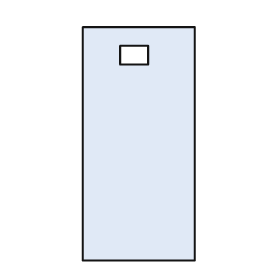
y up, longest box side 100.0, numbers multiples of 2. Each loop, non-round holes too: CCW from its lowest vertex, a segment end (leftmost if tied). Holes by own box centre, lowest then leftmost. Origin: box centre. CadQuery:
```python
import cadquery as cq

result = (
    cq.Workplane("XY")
    .moveTo(-24.0, -50.0)
    .lineTo(24.0, -50.0)
    .lineTo(24.0, 50.0)
    .lineTo(-24.0, 50.0)
    .close()
    .moveTo(-8.0, 34.0)
    .lineTo(4.0, 34.0)
    .lineTo(4.0, 42.0)
    .lineTo(-8.0, 42.0)
    .close()
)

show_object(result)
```